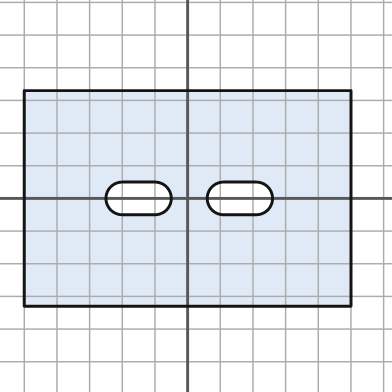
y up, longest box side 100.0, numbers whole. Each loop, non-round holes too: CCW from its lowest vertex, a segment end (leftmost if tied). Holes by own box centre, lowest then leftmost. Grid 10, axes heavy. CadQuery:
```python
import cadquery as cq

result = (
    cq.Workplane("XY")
    .moveTo(-50.0, -33.0)
    .lineTo(50.0, -33.0)
    .lineTo(50.0, 33.0)
    .lineTo(-50.0, 33.0)
    .close()
    .moveTo(-20.0, -5.0)
    .lineTo(-10.0, -5.0)
    .threePointArc((-5.0, 0.0), (-10.0, 5.0))
    .lineTo(-20.0, 5.0)
    .threePointArc((-25.0, 0.0), (-20.0, -5.0))
    .close()
    .moveTo(11.0, -5.0)
    .lineTo(21.0, -5.0)
    .threePointArc((26.0, 0.0), (21.0, 5.0))
    .lineTo(11.0, 5.0)
    .threePointArc((6.0, 0.0), (11.0, -5.0))
    .close()
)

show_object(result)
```